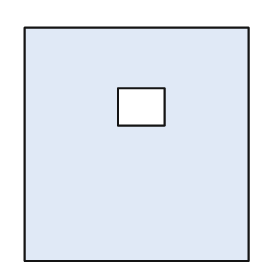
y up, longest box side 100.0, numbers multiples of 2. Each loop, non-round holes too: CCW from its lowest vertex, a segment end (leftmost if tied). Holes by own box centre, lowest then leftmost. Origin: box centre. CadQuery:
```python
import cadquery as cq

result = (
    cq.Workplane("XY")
    .moveTo(-48.0, -50.0)
    .lineTo(48.0, -50.0)
    .lineTo(48.0, 50.0)
    .lineTo(-48.0, 50.0)
    .close()
    .moveTo(-8.0, 8.0)
    .lineTo(12.0, 8.0)
    .lineTo(12.0, 24.0)
    .lineTo(-8.0, 24.0)
    .close()
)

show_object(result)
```